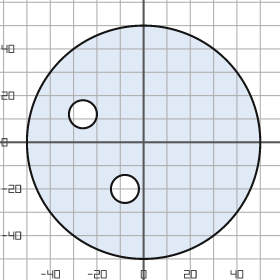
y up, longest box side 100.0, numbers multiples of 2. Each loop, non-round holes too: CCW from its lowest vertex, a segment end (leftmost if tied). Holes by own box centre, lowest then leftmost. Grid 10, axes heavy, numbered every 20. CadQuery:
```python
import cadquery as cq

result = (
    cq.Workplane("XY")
    .moveTo(0.0, 0.0)
    .circle(50.0)
    .moveTo(-8.0, -20.0)
    .circle(6.0)
    .moveTo(-26.0, 12.0)
    .circle(6.0)
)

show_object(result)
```